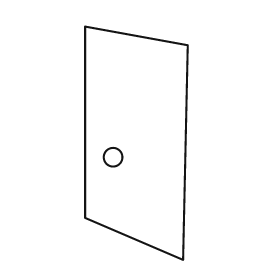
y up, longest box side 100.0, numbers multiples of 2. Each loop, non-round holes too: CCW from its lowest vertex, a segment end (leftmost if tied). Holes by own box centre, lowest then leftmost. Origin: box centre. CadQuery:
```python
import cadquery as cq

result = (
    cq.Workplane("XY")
    .moveTo(20.0, -50.0)
    .lineTo(22.0, 42.0)
    .lineTo(-22.0, 50.0)
    .lineTo(-22.0, -32.0)
    .close()
    .moveTo(-10.0, -6.0)
    .circle(4.0)
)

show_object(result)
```